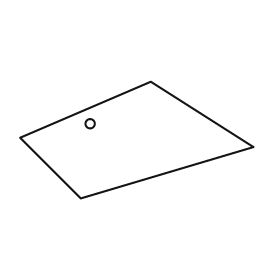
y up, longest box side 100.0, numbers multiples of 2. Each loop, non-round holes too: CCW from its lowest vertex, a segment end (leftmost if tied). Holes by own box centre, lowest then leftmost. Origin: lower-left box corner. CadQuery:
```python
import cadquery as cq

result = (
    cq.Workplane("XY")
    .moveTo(26.0, 0.0)
    .lineTo(100.0, 22.0)
    .lineTo(56.0, 50.0)
    .lineTo(0.0, 26.0)
    .close()
    .moveTo(30.0, 32.0)
    .circle(2.0)
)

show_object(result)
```